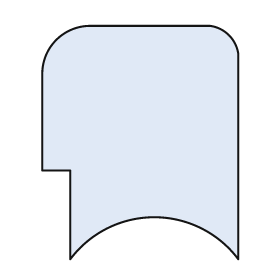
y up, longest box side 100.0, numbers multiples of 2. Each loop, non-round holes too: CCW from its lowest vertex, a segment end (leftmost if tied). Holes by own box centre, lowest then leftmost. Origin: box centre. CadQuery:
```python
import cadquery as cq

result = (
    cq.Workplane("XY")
    .moveTo(-30.0, -50.0)
    .threePointArc((6.0, -32.0), (42.0, -50.0))
    .lineTo(42.0, 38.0)
    .threePointArc((38.0, 46.0), (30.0, 50.0))
    .lineTo(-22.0, 50.0)
    .threePointArc((-36.0, 44.0), (-42.0, 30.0))
    .lineTo(-42.0, -12.0)
    .lineTo(-30.0, -12.0)
    .close()
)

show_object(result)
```